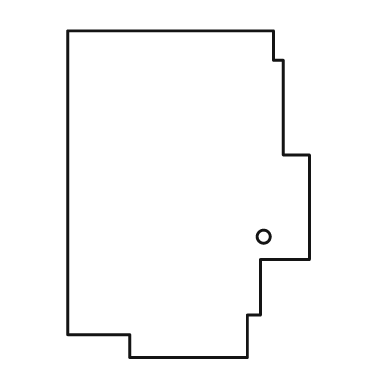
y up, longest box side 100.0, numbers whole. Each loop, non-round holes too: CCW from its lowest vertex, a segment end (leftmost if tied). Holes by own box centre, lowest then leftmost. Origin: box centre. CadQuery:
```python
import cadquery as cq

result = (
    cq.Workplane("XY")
    .moveTo(-18.0, -50.0)
    .lineTo(18.0, -50.0)
    .lineTo(18.0, -37.0)
    .lineTo(22.0, -37.0)
    .lineTo(22.0, -20.0)
    .lineTo(37.0, -20.0)
    .lineTo(37.0, 12.0)
    .lineTo(29.0, 12.0)
    .lineTo(29.0, 41.0)
    .lineTo(26.0, 41.0)
    .lineTo(26.0, 50.0)
    .lineTo(-37.0, 50.0)
    .lineTo(-37.0, -43.0)
    .lineTo(-18.0, -43.0)
    .close()
    .moveTo(23.0, -13.0)
    .circle(2.0)
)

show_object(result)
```